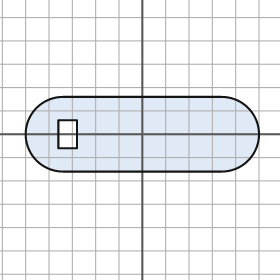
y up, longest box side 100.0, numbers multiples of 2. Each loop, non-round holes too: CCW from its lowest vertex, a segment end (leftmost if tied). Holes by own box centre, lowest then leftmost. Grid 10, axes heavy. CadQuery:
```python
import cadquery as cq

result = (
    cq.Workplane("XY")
    .moveTo(-34.0, -16.0)
    .lineTo(34.0, -16.0)
    .threePointArc((50.0, 0.0), (34.0, 16.0))
    .lineTo(-34.0, 16.0)
    .threePointArc((-50.0, 0.0), (-34.0, -16.0))
    .close()
    .moveTo(-36.0, -6.0)
    .lineTo(-28.0, -6.0)
    .lineTo(-28.0, 6.0)
    .lineTo(-36.0, 6.0)
    .close()
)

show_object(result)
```